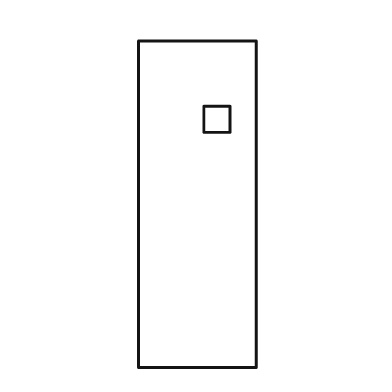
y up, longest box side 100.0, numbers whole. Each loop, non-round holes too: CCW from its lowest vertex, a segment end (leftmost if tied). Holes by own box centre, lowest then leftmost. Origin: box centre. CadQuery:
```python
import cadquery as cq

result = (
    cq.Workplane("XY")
    .moveTo(-18.0, -50.0)
    .lineTo(18.0, -50.0)
    .lineTo(18.0, 50.0)
    .lineTo(-18.0, 50.0)
    .close()
    .moveTo(2.0, 22.0)
    .lineTo(10.0, 22.0)
    .lineTo(10.0, 30.0)
    .lineTo(2.0, 30.0)
    .close()
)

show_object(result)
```